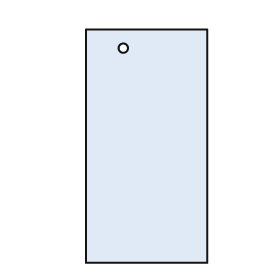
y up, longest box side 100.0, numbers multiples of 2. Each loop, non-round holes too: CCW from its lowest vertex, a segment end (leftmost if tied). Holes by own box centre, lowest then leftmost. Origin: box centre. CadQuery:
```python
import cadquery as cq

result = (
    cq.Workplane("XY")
    .moveTo(-26.0, -50.0)
    .lineTo(26.0, -50.0)
    .lineTo(26.0, 50.0)
    .lineTo(-26.0, 50.0)
    .close()
    .moveTo(-10.0, 42.0)
    .circle(2.0)
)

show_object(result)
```